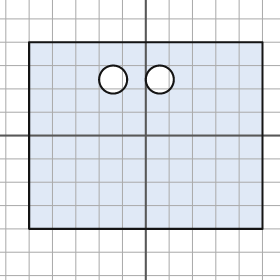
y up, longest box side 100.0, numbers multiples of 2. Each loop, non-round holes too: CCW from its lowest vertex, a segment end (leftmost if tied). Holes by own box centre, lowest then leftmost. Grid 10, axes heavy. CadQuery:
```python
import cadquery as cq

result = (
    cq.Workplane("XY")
    .moveTo(-50.0, -40.0)
    .lineTo(50.0, -40.0)
    .lineTo(50.0, 40.0)
    .lineTo(-50.0, 40.0)
    .close()
    .moveTo(-14.0, 24.0)
    .circle(6.0)
    .moveTo(6.0, 24.0)
    .circle(6.0)
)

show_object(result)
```